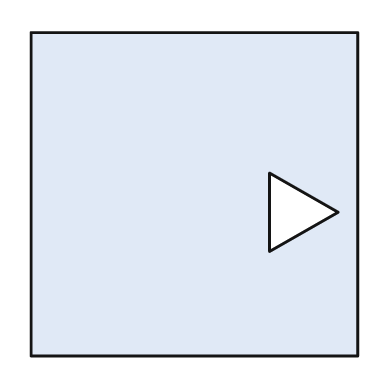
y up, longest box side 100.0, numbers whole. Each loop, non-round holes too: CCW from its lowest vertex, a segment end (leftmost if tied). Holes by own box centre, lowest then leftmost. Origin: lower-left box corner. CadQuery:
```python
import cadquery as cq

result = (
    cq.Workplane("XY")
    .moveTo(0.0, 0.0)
    .lineTo(100.0, 0.0)
    .lineTo(100.0, 99.0)
    .lineTo(0.0, 99.0)
    .close()
    .moveTo(73.0, 32.0)
    .lineTo(94.0, 44.0)
    .lineTo(73.0, 56.0)
    .close()
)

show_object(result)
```